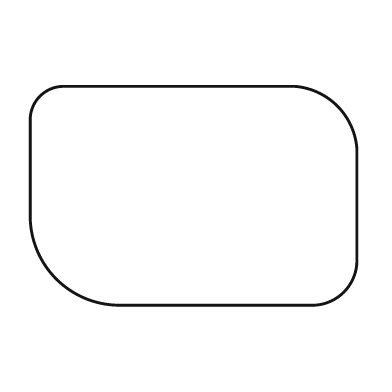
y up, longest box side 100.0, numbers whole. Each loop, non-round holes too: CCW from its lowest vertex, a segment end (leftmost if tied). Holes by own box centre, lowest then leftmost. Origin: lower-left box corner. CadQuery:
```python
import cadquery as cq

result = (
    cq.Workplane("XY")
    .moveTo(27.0, 0.0)
    .lineTo(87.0, 0.0)
    .threePointArc((96.0, 4.0), (100.0, 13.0))
    .lineTo(100.0, 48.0)
    .threePointArc((94.0, 61.0), (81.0, 67.0))
    .lineTo(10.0, 67.0)
    .threePointArc((3.0, 64.0), (0.0, 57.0))
    .lineTo(0.0, 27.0)
    .threePointArc((8.0, 8.0), (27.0, 0.0))
    .close()
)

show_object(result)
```